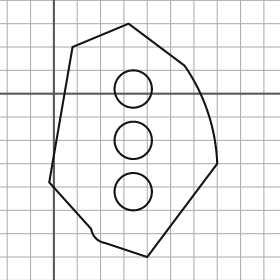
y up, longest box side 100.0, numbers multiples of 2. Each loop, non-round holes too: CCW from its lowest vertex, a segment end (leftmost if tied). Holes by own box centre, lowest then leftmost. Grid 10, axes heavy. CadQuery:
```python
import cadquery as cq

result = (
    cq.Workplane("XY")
    .moveTo(40.0, -70.0)
    .lineTo(70.0, -30.0)
    .threePointArc((66.0, -8.0), (56.0, 12.0))
    .lineTo(32.0, 30.0)
    .lineTo(8.0, 20.0)
    .lineTo(-2.0, -38.0)
    .lineTo(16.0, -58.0)
    .threePointArc((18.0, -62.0), (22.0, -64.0))
    .close()
    .moveTo(34.0, -42.0)
    .circle(8.0)
    .moveTo(34.0, -20.0)
    .circle(8.0)
    .moveTo(34.0, 2.0)
    .circle(8.0)
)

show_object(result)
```